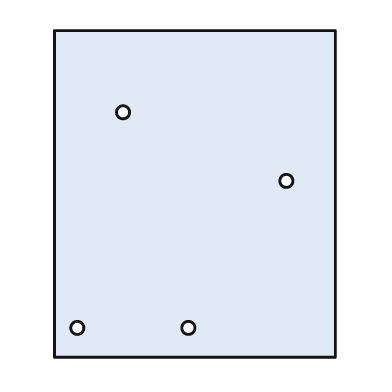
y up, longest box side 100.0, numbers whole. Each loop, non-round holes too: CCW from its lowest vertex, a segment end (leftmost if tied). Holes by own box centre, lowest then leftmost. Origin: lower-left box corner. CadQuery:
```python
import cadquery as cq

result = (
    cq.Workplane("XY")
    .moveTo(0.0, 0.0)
    .lineTo(86.0, 0.0)
    .lineTo(86.0, 100.0)
    .lineTo(0.0, 100.0)
    .close()
    .moveTo(7.0, 9.0)
    .circle(2.0)
    .moveTo(41.0, 9.0)
    .circle(2.0)
    .moveTo(71.0, 54.0)
    .circle(2.0)
    .moveTo(21.0, 75.0)
    .circle(2.0)
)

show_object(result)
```